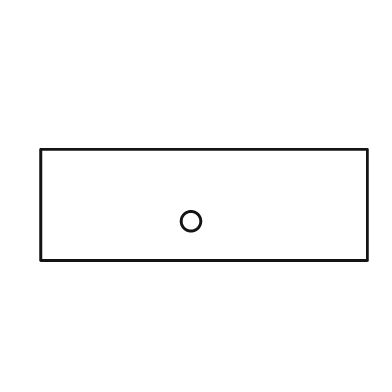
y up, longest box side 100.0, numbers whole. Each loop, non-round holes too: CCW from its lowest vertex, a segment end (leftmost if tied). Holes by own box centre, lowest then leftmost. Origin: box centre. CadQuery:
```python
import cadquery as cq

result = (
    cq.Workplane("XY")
    .moveTo(-50.0, -17.0)
    .lineTo(50.0, -17.0)
    .lineTo(50.0, 17.0)
    .lineTo(-50.0, 17.0)
    .close()
    .moveTo(-4.0, -5.0)
    .circle(3.0)
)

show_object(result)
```